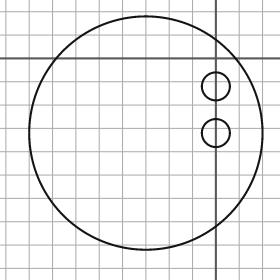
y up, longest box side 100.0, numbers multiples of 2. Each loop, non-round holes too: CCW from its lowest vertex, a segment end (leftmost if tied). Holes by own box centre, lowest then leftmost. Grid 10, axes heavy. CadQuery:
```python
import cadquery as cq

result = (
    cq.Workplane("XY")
    .moveTo(-30.0, -32.0)
    .circle(50.0)
    .moveTo(0.0, -32.0)
    .circle(6.0)
    .moveTo(0.0, -12.0)
    .circle(6.0)
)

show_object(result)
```